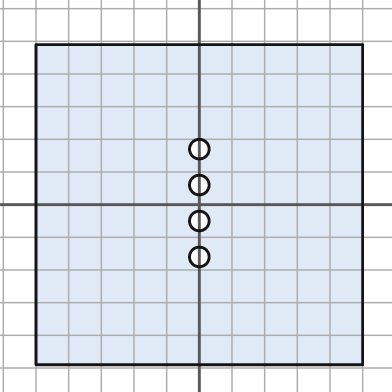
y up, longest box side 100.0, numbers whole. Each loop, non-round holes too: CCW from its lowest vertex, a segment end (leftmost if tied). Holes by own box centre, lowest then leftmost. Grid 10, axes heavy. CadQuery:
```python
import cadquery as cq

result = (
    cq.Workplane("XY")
    .moveTo(-50.0, -49.0)
    .lineTo(50.0, -49.0)
    .lineTo(50.0, 49.0)
    .lineTo(-50.0, 49.0)
    .close()
    .moveTo(0.0, -16.0)
    .circle(3.0)
    .moveTo(0.0, -5.0)
    .circle(3.0)
    .moveTo(0.0, 6.0)
    .circle(3.0)
    .moveTo(0.0, 17.0)
    .circle(3.0)
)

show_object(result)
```